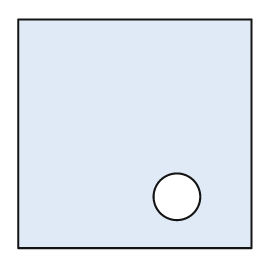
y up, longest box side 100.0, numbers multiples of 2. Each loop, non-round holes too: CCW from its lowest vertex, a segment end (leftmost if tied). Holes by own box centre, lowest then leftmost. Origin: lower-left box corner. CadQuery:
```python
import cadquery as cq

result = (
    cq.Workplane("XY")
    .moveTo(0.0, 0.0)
    .lineTo(100.0, 0.0)
    .lineTo(100.0, 98.0)
    .lineTo(0.0, 98.0)
    .close()
    .moveTo(68.0, 22.0)
    .circle(10.0)
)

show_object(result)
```